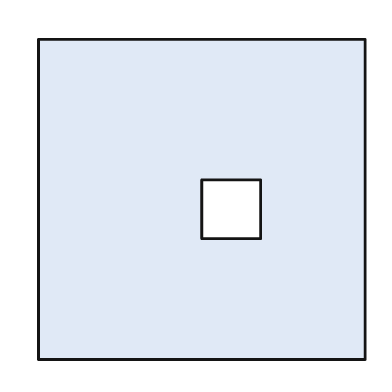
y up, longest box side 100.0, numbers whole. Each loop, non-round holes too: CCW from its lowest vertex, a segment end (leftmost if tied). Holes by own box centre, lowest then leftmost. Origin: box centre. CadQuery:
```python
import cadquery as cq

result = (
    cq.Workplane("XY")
    .moveTo(-50.0, -49.0)
    .lineTo(50.0, -49.0)
    .lineTo(50.0, 49.0)
    .lineTo(-50.0, 49.0)
    .close()
    .moveTo(0.0, -12.0)
    .lineTo(18.0, -12.0)
    .lineTo(18.0, 6.0)
    .lineTo(0.0, 6.0)
    .close()
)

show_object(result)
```